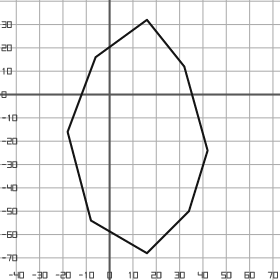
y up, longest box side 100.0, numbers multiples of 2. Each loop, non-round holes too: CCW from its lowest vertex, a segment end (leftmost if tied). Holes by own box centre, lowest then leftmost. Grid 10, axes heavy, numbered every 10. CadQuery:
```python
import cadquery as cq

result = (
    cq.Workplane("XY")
    .moveTo(16.0, -68.0)
    .lineTo(34.0, -50.0)
    .lineTo(42.0, -24.0)
    .lineTo(32.0, 12.0)
    .lineTo(16.0, 32.0)
    .lineTo(-6.0, 16.0)
    .lineTo(-18.0, -16.0)
    .lineTo(-8.0, -54.0)
    .close()
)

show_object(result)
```